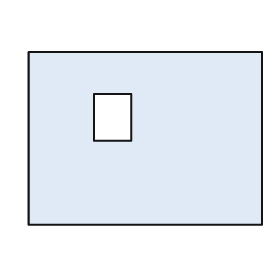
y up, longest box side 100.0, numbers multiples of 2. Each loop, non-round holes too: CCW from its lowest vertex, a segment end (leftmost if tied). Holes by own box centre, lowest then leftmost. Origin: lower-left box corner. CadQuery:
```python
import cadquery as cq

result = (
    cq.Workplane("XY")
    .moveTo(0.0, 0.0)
    .lineTo(100.0, 0.0)
    .lineTo(100.0, 74.0)
    .lineTo(0.0, 74.0)
    .close()
    .moveTo(28.0, 36.0)
    .lineTo(44.0, 36.0)
    .lineTo(44.0, 56.0)
    .lineTo(28.0, 56.0)
    .close()
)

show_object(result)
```